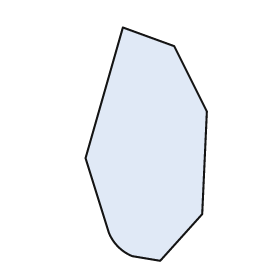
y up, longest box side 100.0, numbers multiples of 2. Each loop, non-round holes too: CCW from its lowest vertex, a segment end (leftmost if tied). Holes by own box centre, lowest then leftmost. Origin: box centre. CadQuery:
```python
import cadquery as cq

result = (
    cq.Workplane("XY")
    .moveTo(6.0, -50.0)
    .lineTo(24.0, -30.0)
    .lineTo(26.0, 14.0)
    .lineTo(12.0, 42.0)
    .lineTo(-10.0, 50.0)
    .lineTo(-26.0, -6.0)
    .lineTo(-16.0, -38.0)
    .threePointArc((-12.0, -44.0), (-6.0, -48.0))
    .close()
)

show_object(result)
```